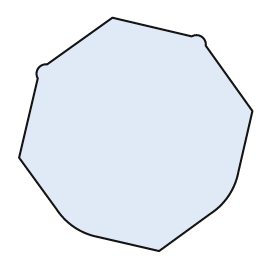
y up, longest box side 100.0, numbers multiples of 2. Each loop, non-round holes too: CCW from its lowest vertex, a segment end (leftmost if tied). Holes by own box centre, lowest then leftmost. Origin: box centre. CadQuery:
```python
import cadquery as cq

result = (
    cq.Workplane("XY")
    .moveTo(10.0, -50.0)
    .lineTo(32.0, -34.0)
    .threePointArc((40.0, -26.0), (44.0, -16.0))
    .lineTo(50.0, 10.0)
    .lineTo(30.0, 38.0)
    .threePointArc((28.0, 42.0), (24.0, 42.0))
    .lineTo(-10.0, 50.0)
    .lineTo(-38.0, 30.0)
    .threePointArc((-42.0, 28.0), (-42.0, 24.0))
    .lineTo(-50.0, -10.0)
    .lineTo(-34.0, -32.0)
    .threePointArc((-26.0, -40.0), (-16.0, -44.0))
    .close()
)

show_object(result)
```